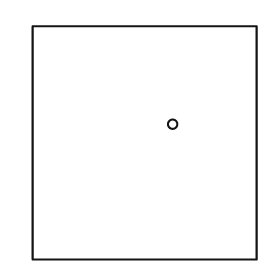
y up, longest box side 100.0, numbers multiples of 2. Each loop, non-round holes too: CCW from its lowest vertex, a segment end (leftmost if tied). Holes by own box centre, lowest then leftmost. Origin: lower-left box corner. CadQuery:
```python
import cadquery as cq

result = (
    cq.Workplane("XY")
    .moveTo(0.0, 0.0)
    .lineTo(96.0, 0.0)
    .lineTo(96.0, 100.0)
    .lineTo(0.0, 100.0)
    .close()
    .moveTo(60.0, 58.0)
    .circle(2.0)
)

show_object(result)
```